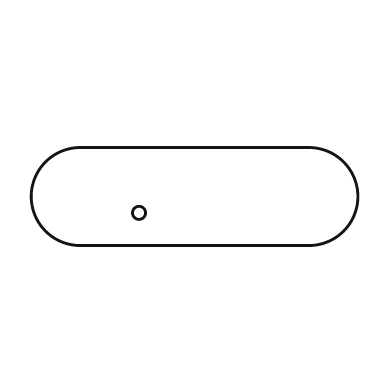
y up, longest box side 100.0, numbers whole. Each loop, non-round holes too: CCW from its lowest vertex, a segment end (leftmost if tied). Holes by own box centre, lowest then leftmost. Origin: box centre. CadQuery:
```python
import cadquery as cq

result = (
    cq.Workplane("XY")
    .moveTo(-35.0, -15.0)
    .lineTo(35.0, -15.0)
    .threePointArc((50.0, 0.0), (35.0, 15.0))
    .lineTo(-35.0, 15.0)
    .threePointArc((-50.0, 0.0), (-35.0, -15.0))
    .close()
    .moveTo(-17.0, -5.0)
    .circle(2.0)
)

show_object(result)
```